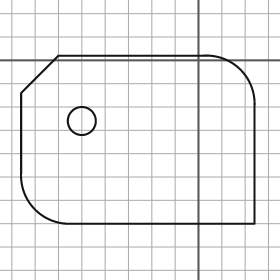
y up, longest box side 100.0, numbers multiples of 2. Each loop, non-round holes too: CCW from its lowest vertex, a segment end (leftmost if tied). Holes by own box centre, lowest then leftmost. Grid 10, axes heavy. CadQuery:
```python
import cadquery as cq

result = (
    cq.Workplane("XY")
    .moveTo(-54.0, -70.0)
    .lineTo(24.0, -70.0)
    .lineTo(24.0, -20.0)
    .threePointArc((18.0, -4.0), (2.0, 2.0))
    .lineTo(-60.0, 2.0)
    .lineTo(-76.0, -14.0)
    .lineTo(-76.0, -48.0)
    .threePointArc((-70.0, -64.0), (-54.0, -70.0))
    .close()
    .moveTo(-50.0, -26.0)
    .circle(6.0)
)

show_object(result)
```